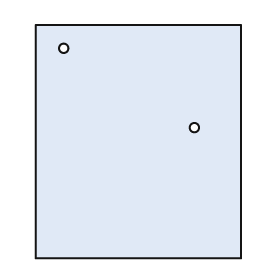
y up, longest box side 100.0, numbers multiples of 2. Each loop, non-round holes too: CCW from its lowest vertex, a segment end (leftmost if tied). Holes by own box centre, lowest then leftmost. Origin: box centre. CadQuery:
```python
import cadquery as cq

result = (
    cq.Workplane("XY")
    .moveTo(-44.0, -50.0)
    .lineTo(44.0, -50.0)
    .lineTo(44.0, 50.0)
    .lineTo(-44.0, 50.0)
    .close()
    .moveTo(24.0, 6.0)
    .circle(2.0)
    .moveTo(-32.0, 40.0)
    .circle(2.0)
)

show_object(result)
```